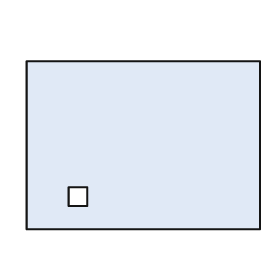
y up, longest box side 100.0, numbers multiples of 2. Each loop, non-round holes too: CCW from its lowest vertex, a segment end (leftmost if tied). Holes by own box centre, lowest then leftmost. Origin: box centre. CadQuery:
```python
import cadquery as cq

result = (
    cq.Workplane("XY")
    .moveTo(-50.0, -36.0)
    .lineTo(50.0, -36.0)
    .lineTo(50.0, 36.0)
    .lineTo(-50.0, 36.0)
    .close()
    .moveTo(-32.0, -26.0)
    .lineTo(-24.0, -26.0)
    .lineTo(-24.0, -18.0)
    .lineTo(-32.0, -18.0)
    .close()
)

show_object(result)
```